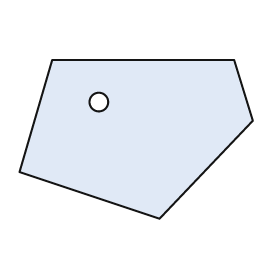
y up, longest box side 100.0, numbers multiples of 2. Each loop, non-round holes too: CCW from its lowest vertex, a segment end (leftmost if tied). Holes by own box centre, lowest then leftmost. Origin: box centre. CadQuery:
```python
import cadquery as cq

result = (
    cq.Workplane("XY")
    .moveTo(10.0, -34.0)
    .lineTo(50.0, 8.0)
    .lineTo(42.0, 34.0)
    .lineTo(-36.0, 34.0)
    .lineTo(-50.0, -14.0)
    .close()
    .moveTo(-16.0, 16.0)
    .circle(4.0)
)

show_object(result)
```